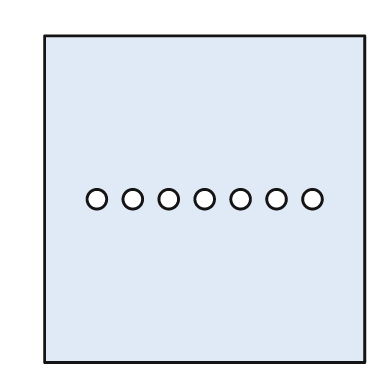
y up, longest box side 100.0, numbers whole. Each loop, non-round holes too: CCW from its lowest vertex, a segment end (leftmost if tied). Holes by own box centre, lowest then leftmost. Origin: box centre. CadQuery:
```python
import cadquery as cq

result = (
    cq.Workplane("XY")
    .moveTo(-49.0, -50.0)
    .lineTo(49.0, -50.0)
    .lineTo(49.0, 50.0)
    .lineTo(-49.0, 50.0)
    .close()
    .moveTo(-33.0, 0.0)
    .circle(3.0)
    .moveTo(-22.0, 0.0)
    .circle(3.0)
    .moveTo(-11.0, 0.0)
    .circle(3.0)
    .moveTo(0.0, 0.0)
    .circle(3.0)
    .moveTo(11.0, 0.0)
    .circle(3.0)
    .moveTo(22.0, 0.0)
    .circle(3.0)
    .moveTo(33.0, 0.0)
    .circle(3.0)
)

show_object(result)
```